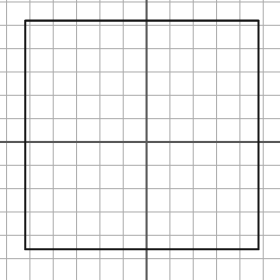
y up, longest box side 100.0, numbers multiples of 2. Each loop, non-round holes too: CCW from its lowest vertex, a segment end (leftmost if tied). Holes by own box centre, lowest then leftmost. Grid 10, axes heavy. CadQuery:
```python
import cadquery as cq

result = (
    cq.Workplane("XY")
    .moveTo(-52.0, -46.0)
    .lineTo(48.0, -46.0)
    .lineTo(48.0, 52.0)
    .lineTo(-52.0, 52.0)
    .close()
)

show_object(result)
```